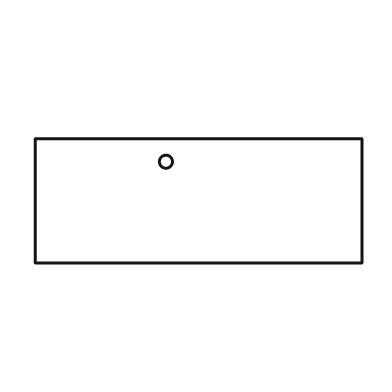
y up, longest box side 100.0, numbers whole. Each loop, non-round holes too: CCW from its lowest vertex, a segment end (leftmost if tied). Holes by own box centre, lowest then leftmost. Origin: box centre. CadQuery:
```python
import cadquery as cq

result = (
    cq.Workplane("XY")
    .moveTo(-50.0, -19.0)
    .lineTo(50.0, -19.0)
    .lineTo(50.0, 19.0)
    .lineTo(-50.0, 19.0)
    .close()
    .moveTo(-10.0, 12.0)
    .circle(2.0)
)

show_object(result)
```